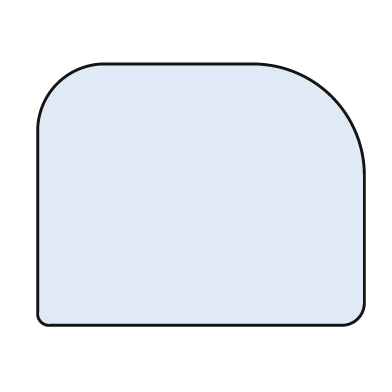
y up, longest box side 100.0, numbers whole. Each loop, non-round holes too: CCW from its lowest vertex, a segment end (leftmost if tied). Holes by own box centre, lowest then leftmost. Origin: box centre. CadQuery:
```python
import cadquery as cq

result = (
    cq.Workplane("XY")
    .moveTo(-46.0, -40.0)
    .lineTo(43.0, -40.0)
    .threePointArc((48.0, -38.0), (50.0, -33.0))
    .lineTo(50.0, 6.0)
    .threePointArc((40.0, 30.0), (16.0, 40.0))
    .lineTo(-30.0, 40.0)
    .threePointArc((-44.0, 34.0), (-50.0, 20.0))
    .lineTo(-50.0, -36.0)
    .threePointArc((-49.0, -39.0), (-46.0, -40.0))
    .close()
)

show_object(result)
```